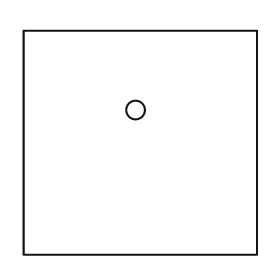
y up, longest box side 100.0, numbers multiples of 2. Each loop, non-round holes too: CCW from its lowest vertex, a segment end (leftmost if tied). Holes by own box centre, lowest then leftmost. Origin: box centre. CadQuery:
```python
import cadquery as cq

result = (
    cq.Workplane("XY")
    .moveTo(-50.0, -48.0)
    .lineTo(50.0, -48.0)
    .lineTo(50.0, 48.0)
    .lineTo(-50.0, 48.0)
    .close()
    .moveTo(-2.0, 14.0)
    .circle(4.0)
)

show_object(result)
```